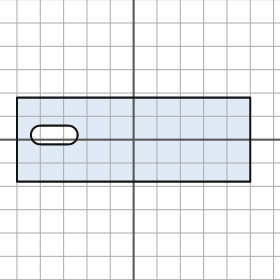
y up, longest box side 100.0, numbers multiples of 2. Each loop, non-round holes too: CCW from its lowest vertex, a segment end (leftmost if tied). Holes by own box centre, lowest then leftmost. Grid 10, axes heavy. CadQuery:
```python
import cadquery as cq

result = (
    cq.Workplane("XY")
    .moveTo(-50.0, -18.0)
    .lineTo(50.0, -18.0)
    .lineTo(50.0, 18.0)
    .lineTo(-50.0, 18.0)
    .close()
    .moveTo(-40.0, -2.0)
    .lineTo(-28.0, -2.0)
    .threePointArc((-24.0, 2.0), (-28.0, 6.0))
    .lineTo(-40.0, 6.0)
    .threePointArc((-44.0, 2.0), (-40.0, -2.0))
    .close()
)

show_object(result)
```